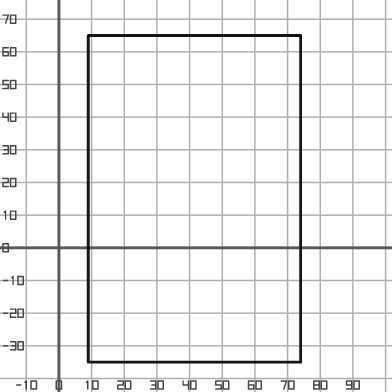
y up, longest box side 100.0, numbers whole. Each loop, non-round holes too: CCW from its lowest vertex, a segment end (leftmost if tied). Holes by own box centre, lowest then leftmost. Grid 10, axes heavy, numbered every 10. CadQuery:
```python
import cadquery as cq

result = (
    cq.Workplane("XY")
    .moveTo(9.0, -35.0)
    .lineTo(74.0, -35.0)
    .lineTo(74.0, 65.0)
    .lineTo(9.0, 65.0)
    .close()
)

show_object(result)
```